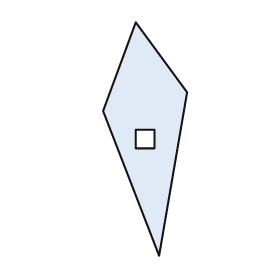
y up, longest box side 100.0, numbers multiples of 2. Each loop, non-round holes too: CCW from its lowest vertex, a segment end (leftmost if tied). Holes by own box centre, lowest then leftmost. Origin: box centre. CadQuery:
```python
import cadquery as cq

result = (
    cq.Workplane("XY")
    .moveTo(6.0, -50.0)
    .lineTo(18.0, 20.0)
    .lineTo(-4.0, 50.0)
    .lineTo(-18.0, 12.0)
    .close()
    .moveTo(-4.0, -4.0)
    .lineTo(4.0, -4.0)
    .lineTo(4.0, 4.0)
    .lineTo(-4.0, 4.0)
    .close()
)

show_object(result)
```